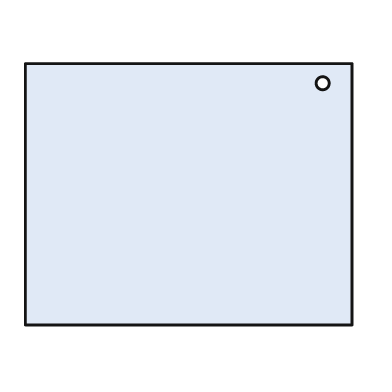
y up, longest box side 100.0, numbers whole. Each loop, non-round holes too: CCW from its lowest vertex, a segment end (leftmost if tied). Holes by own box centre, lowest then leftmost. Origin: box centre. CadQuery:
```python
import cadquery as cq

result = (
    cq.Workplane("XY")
    .moveTo(-50.0, -40.0)
    .lineTo(50.0, -40.0)
    .lineTo(50.0, 40.0)
    .lineTo(-50.0, 40.0)
    .close()
    .moveTo(41.0, 34.0)
    .circle(2.0)
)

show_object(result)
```